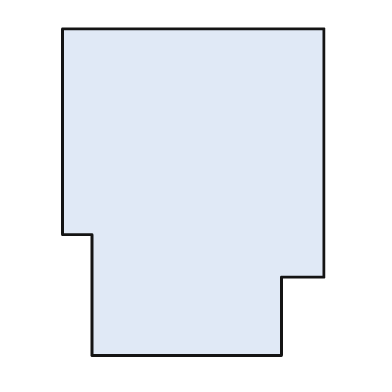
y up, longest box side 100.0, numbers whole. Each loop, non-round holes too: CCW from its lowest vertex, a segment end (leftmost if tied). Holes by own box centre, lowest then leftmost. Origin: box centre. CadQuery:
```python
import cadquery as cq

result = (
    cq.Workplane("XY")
    .moveTo(-31.0, -50.0)
    .lineTo(27.0, -50.0)
    .lineTo(27.0, -26.0)
    .lineTo(40.0, -26.0)
    .lineTo(40.0, 50.0)
    .lineTo(-40.0, 50.0)
    .lineTo(-40.0, -13.0)
    .lineTo(-31.0, -13.0)
    .close()
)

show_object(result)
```